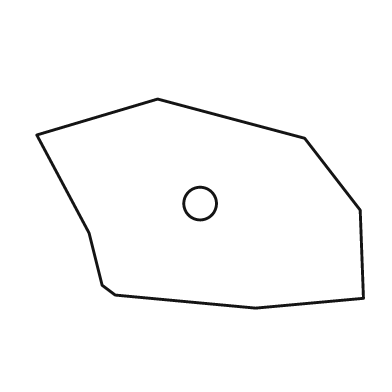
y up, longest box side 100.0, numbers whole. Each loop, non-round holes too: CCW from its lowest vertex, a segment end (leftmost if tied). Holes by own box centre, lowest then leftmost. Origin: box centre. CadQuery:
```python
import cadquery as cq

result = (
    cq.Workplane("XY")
    .moveTo(17.0, -32.0)
    .lineTo(50.0, -29.0)
    .lineTo(49.0, -2.0)
    .lineTo(32.0, 20.0)
    .lineTo(-13.0, 32.0)
    .lineTo(-50.0, 21.0)
    .lineTo(-34.0, -9.0)
    .lineTo(-30.0, -25.0)
    .lineTo(-26.0, -28.0)
    .close()
    .moveTo(0.0, 0.0)
    .circle(5.0)
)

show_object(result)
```